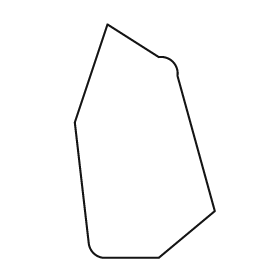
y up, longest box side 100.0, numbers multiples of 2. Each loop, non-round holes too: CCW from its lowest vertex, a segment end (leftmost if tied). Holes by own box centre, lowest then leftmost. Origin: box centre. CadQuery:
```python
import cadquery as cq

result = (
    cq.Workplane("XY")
    .moveTo(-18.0, -50.0)
    .lineTo(6.0, -50.0)
    .lineTo(30.0, -30.0)
    .lineTo(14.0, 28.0)
    .threePointArc((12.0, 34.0), (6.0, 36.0))
    .lineTo(-16.0, 50.0)
    .lineTo(-30.0, 8.0)
    .lineTo(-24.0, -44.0)
    .threePointArc((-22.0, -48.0), (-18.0, -50.0))
    .close()
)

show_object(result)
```